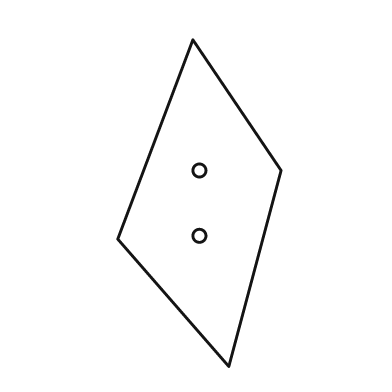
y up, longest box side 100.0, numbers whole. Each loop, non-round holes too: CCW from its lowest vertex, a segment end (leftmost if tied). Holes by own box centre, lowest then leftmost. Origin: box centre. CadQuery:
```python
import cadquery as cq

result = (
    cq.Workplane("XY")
    .moveTo(9.0, -50.0)
    .lineTo(25.0, 10.0)
    .lineTo(-2.0, 50.0)
    .lineTo(-25.0, -11.0)
    .close()
    .moveTo(0.0, -10.0)
    .circle(2.0)
    .moveTo(0.0, 10.0)
    .circle(2.0)
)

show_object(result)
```